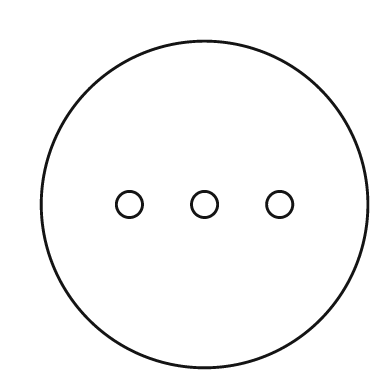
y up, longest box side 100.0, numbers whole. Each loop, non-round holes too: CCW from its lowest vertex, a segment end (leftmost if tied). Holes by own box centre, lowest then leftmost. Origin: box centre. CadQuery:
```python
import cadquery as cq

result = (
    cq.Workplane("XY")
    .moveTo(0.0, 0.0)
    .circle(50.0)
    .moveTo(-23.0, 0.0)
    .circle(4.0)
    .moveTo(0.0, 0.0)
    .circle(4.0)
    .moveTo(23.0, 0.0)
    .circle(4.0)
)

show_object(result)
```